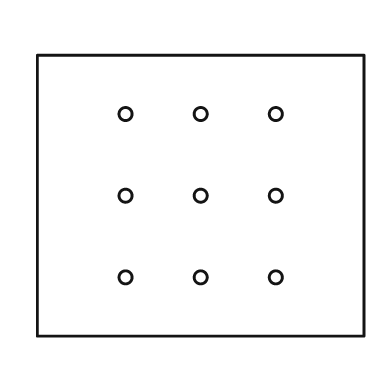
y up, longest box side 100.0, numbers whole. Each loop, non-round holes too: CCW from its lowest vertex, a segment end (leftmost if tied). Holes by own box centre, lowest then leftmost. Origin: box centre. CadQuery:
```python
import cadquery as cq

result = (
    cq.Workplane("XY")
    .moveTo(-50.0, -43.0)
    .lineTo(50.0, -43.0)
    .lineTo(50.0, 43.0)
    .lineTo(-50.0, 43.0)
    .close()
    .moveTo(-23.0, -25.0)
    .circle(2.0)
    .moveTo(0.0, -25.0)
    .circle(2.0)
    .moveTo(23.0, -25.0)
    .circle(2.0)
    .moveTo(-23.0, 0.0)
    .circle(2.0)
    .moveTo(0.0, 0.0)
    .circle(2.0)
    .moveTo(23.0, 0.0)
    .circle(2.0)
    .moveTo(-23.0, 25.0)
    .circle(2.0)
    .moveTo(0.0, 25.0)
    .circle(2.0)
    .moveTo(23.0, 25.0)
    .circle(2.0)
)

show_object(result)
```